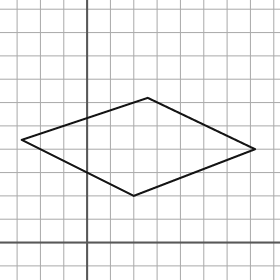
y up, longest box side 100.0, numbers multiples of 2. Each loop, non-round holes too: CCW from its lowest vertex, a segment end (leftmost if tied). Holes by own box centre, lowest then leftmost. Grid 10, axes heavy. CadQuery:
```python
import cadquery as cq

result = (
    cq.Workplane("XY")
    .moveTo(20.0, 20.0)
    .lineTo(72.0, 40.0)
    .lineTo(26.0, 62.0)
    .lineTo(-28.0, 44.0)
    .close()
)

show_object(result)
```